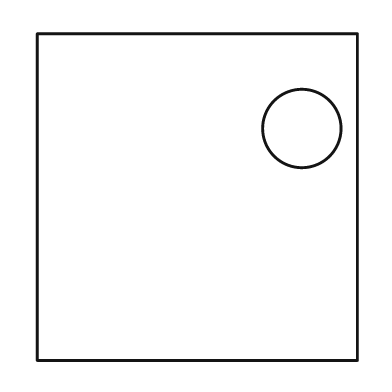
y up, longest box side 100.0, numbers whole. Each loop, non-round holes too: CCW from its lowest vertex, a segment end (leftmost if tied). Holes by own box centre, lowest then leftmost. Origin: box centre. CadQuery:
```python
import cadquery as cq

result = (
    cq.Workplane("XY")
    .moveTo(-49.0, -50.0)
    .lineTo(49.0, -50.0)
    .lineTo(49.0, 50.0)
    .lineTo(-49.0, 50.0)
    .close()
    .moveTo(32.0, 21.0)
    .circle(12.0)
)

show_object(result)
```